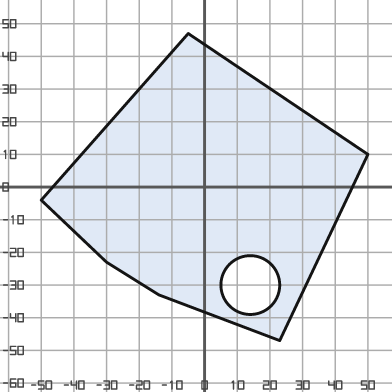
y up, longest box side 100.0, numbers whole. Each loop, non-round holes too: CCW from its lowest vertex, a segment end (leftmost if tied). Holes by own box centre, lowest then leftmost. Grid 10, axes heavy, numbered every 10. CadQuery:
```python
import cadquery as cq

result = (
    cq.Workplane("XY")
    .moveTo(23.0, -47.0)
    .lineTo(50.0, 10.0)
    .lineTo(-5.0, 47.0)
    .lineTo(-50.0, -4.0)
    .lineTo(-30.0, -23.0)
    .lineTo(-14.0, -33.0)
    .close()
    .moveTo(14.0, -30.0)
    .circle(9.0)
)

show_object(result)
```